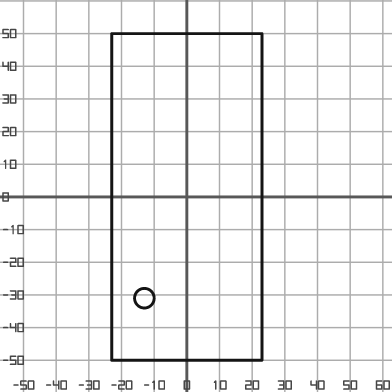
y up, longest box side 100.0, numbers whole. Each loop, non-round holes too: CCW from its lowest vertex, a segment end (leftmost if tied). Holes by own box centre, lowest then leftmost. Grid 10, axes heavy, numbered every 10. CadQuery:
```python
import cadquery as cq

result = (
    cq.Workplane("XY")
    .moveTo(-23.0, -50.0)
    .lineTo(23.0, -50.0)
    .lineTo(23.0, 50.0)
    .lineTo(-23.0, 50.0)
    .close()
    .moveTo(-13.0, -31.0)
    .circle(3.0)
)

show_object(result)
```